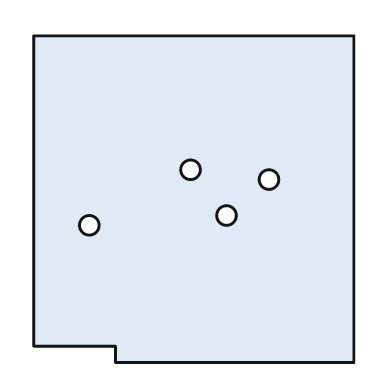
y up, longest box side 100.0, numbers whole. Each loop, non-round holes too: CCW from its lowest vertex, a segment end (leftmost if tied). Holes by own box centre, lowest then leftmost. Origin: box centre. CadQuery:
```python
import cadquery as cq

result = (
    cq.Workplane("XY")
    .moveTo(-24.0, -50.0)
    .lineTo(49.0, -50.0)
    .lineTo(49.0, 50.0)
    .lineTo(-49.0, 50.0)
    .lineTo(-49.0, -45.0)
    .lineTo(-24.0, -45.0)
    .close()
    .moveTo(-32.0, -8.0)
    .circle(3.0)
    .moveTo(10.0, -5.0)
    .circle(3.0)
    .moveTo(23.0, 6.0)
    .circle(3.0)
    .moveTo(-1.0, 9.0)
    .circle(3.0)
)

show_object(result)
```